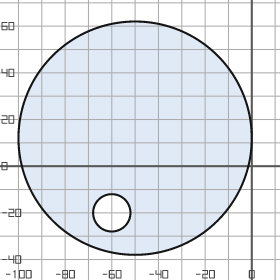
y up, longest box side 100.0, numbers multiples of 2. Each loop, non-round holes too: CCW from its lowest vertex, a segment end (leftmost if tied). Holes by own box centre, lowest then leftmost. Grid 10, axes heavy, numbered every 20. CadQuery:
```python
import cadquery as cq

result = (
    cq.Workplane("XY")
    .moveTo(-50.0, 12.0)
    .circle(50.0)
    .moveTo(-60.0, -20.0)
    .circle(8.0)
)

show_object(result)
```